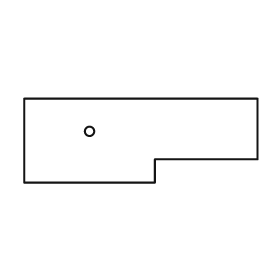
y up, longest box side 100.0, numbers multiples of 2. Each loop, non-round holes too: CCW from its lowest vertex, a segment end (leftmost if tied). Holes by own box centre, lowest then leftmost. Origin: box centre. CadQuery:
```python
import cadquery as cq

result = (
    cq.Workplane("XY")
    .moveTo(-50.0, -18.0)
    .lineTo(6.0, -18.0)
    .lineTo(6.0, -8.0)
    .lineTo(50.0, -8.0)
    .lineTo(50.0, 18.0)
    .lineTo(-50.0, 18.0)
    .close()
    .moveTo(-22.0, 4.0)
    .circle(2.0)
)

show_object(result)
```